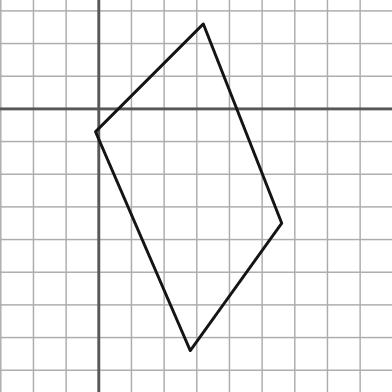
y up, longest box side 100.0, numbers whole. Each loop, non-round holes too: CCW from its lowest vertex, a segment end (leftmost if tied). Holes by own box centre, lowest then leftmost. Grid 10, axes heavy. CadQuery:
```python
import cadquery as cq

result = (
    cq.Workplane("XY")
    .moveTo(28.0, -74.0)
    .lineTo(56.0, -35.0)
    .lineTo(32.0, 26.0)
    .lineTo(-1.0, -7.0)
    .close()
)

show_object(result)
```